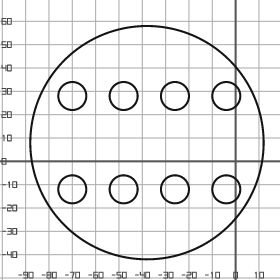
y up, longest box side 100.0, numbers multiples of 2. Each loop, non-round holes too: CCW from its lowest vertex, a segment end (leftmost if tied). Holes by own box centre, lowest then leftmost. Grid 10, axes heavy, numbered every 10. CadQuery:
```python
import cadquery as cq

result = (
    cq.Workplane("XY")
    .moveTo(-38.0, 8.0)
    .circle(50.0)
    .moveTo(-70.0, -12.0)
    .circle(6.0)
    .moveTo(-48.0, -12.0)
    .circle(6.0)
    .moveTo(-26.0, -12.0)
    .circle(6.0)
    .moveTo(-4.0, -12.0)
    .circle(6.0)
    .moveTo(-70.0, 28.0)
    .circle(6.0)
    .moveTo(-48.0, 28.0)
    .circle(6.0)
    .moveTo(-26.0, 28.0)
    .circle(6.0)
    .moveTo(-4.0, 28.0)
    .circle(6.0)
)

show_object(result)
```